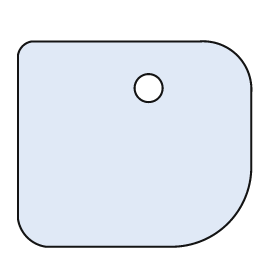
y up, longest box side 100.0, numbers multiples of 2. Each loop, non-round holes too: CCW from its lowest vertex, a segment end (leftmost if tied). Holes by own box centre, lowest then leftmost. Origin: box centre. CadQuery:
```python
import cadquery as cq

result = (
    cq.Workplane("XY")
    .moveTo(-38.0, -44.0)
    .lineTo(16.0, -44.0)
    .threePointArc((40.0, -34.0), (50.0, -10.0))
    .lineTo(50.0, 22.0)
    .threePointArc((44.0, 38.0), (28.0, 44.0))
    .lineTo(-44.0, 44.0)
    .threePointArc((-48.0, 42.0), (-50.0, 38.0))
    .lineTo(-50.0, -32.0)
    .threePointArc((-46.0, -40.0), (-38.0, -44.0))
    .close()
    .moveTo(6.0, 24.0)
    .circle(6.0)
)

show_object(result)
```